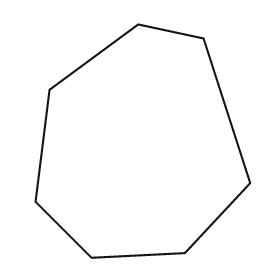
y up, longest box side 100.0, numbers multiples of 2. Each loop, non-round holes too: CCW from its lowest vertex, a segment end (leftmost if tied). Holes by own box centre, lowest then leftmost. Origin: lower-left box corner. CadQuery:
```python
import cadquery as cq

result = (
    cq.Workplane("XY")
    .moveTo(24.0, 0.0)
    .lineTo(64.0, 2.0)
    .lineTo(92.0, 32.0)
    .lineTo(72.0, 94.0)
    .lineTo(44.0, 100.0)
    .lineTo(6.0, 72.0)
    .lineTo(0.0, 24.0)
    .close()
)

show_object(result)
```